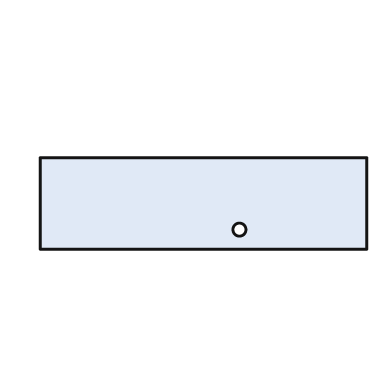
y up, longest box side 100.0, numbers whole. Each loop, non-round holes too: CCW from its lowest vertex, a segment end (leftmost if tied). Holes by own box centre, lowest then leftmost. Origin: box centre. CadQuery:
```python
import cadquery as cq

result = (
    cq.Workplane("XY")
    .moveTo(-50.0, -14.0)
    .lineTo(50.0, -14.0)
    .lineTo(50.0, 14.0)
    .lineTo(-50.0, 14.0)
    .close()
    .moveTo(11.0, -8.0)
    .circle(2.0)
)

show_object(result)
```